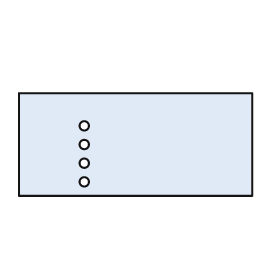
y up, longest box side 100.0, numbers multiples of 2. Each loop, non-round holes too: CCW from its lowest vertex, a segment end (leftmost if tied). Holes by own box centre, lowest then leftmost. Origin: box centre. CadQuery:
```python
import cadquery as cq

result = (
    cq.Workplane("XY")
    .moveTo(-50.0, -22.0)
    .lineTo(50.0, -22.0)
    .lineTo(50.0, 22.0)
    .lineTo(-50.0, 22.0)
    .close()
    .moveTo(-22.0, -16.0)
    .circle(2.0)
    .moveTo(-22.0, -8.0)
    .circle(2.0)
    .moveTo(-22.0, 0.0)
    .circle(2.0)
    .moveTo(-22.0, 8.0)
    .circle(2.0)
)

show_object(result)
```